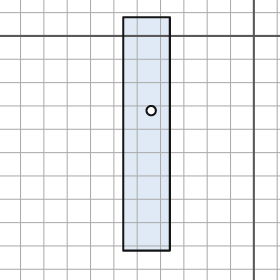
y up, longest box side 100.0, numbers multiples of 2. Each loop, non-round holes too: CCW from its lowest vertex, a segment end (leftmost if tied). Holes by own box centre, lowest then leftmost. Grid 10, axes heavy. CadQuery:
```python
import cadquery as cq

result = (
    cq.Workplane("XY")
    .moveTo(-56.0, -92.0)
    .lineTo(-36.0, -92.0)
    .lineTo(-36.0, 8.0)
    .lineTo(-56.0, 8.0)
    .close()
    .moveTo(-44.0, -32.0)
    .circle(2.0)
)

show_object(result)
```